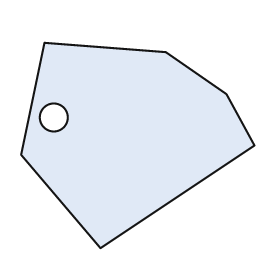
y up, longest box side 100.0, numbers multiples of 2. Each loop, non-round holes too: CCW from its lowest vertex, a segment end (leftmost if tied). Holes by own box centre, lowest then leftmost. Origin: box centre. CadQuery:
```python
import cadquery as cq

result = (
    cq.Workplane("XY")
    .moveTo(-16.0, -44.0)
    .lineTo(50.0, 0.0)
    .lineTo(38.0, 22.0)
    .lineTo(12.0, 40.0)
    .lineTo(-40.0, 44.0)
    .lineTo(-50.0, -4.0)
    .close()
    .moveTo(-36.0, 12.0)
    .circle(6.0)
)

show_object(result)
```